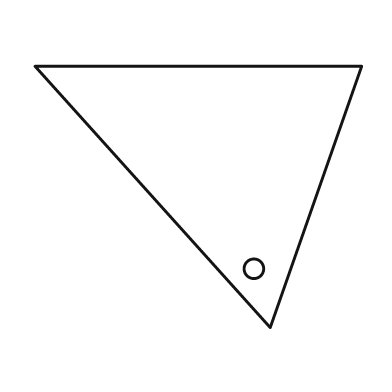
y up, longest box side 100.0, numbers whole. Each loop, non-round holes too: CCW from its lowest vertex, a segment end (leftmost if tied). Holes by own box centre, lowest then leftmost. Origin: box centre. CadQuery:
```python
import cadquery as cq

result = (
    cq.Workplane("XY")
    .moveTo(22.0, -40.0)
    .lineTo(50.0, 40.0)
    .lineTo(-50.0, 40.0)
    .close()
    .moveTo(17.0, -22.0)
    .circle(3.0)
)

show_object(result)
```